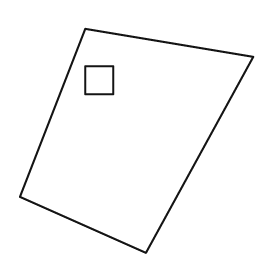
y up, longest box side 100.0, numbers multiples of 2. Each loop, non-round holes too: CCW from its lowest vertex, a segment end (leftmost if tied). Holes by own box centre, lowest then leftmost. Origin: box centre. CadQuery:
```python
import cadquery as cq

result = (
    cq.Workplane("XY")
    .moveTo(4.0, -48.0)
    .lineTo(50.0, 36.0)
    .lineTo(-22.0, 48.0)
    .lineTo(-50.0, -24.0)
    .close()
    .moveTo(-22.0, 20.0)
    .lineTo(-10.0, 20.0)
    .lineTo(-10.0, 32.0)
    .lineTo(-22.0, 32.0)
    .close()
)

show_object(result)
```